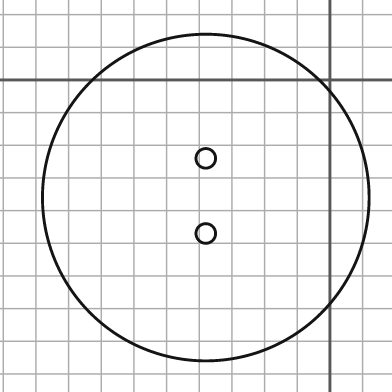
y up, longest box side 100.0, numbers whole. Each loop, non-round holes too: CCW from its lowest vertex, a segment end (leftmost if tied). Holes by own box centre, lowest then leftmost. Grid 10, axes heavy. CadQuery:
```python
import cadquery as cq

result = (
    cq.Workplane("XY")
    .moveTo(-38.0, -36.0)
    .circle(50.0)
    .moveTo(-38.0, -47.0)
    .circle(3.0)
    .moveTo(-38.0, -24.0)
    .circle(3.0)
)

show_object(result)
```